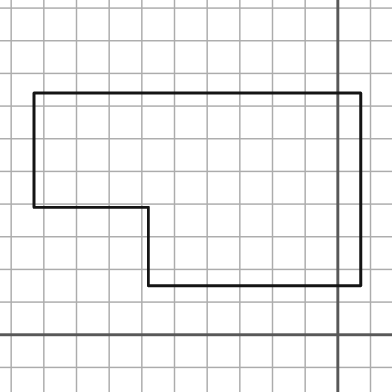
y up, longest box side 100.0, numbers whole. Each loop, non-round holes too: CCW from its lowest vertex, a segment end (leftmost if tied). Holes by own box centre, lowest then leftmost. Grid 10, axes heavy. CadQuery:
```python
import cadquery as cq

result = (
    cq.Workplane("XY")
    .moveTo(-58.0, 15.0)
    .lineTo(7.0, 15.0)
    .lineTo(7.0, 74.0)
    .lineTo(-93.0, 74.0)
    .lineTo(-93.0, 39.0)
    .lineTo(-58.0, 39.0)
    .close()
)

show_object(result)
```